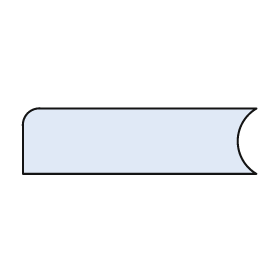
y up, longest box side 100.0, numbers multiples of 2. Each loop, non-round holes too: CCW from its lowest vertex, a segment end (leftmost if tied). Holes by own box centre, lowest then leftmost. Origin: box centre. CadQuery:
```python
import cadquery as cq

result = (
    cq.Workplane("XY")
    .moveTo(-50.0, -14.0)
    .lineTo(50.0, -14.0)
    .threePointArc((42.0, 0.0), (50.0, 14.0))
    .lineTo(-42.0, 14.0)
    .threePointArc((-48.0, 12.0), (-50.0, 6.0))
    .close()
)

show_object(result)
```